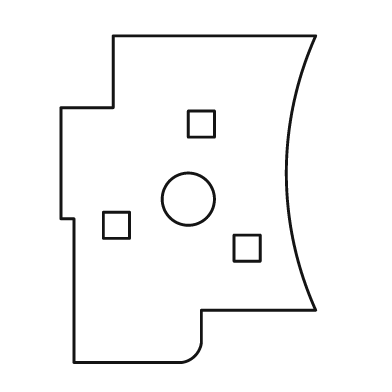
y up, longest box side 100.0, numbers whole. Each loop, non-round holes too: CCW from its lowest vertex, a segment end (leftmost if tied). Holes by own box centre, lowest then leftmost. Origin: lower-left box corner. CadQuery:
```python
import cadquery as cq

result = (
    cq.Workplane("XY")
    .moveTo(4.0, 0.0)
    .lineTo(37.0, 0.0)
    .threePointArc((41.0, 2.0), (43.0, 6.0))
    .lineTo(43.0, 16.0)
    .lineTo(78.0, 16.0)
    .threePointArc((69.0, 58.0), (78.0, 100.0))
    .lineTo(16.0, 100.0)
    .lineTo(16.0, 78.0)
    .lineTo(0.0, 78.0)
    .lineTo(0.0, 44.0)
    .lineTo(4.0, 44.0)
    .close()
    .moveTo(53.0, 31.0)
    .lineTo(61.0, 31.0)
    .lineTo(61.0, 39.0)
    .lineTo(53.0, 39.0)
    .close()
    .moveTo(13.0, 38.0)
    .lineTo(21.0, 38.0)
    .lineTo(21.0, 46.0)
    .lineTo(13.0, 46.0)
    .close()
    .moveTo(39.0, 50.0)
    .circle(8.0)
    .moveTo(39.0, 69.0)
    .lineTo(47.0, 69.0)
    .lineTo(47.0, 77.0)
    .lineTo(39.0, 77.0)
    .close()
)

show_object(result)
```